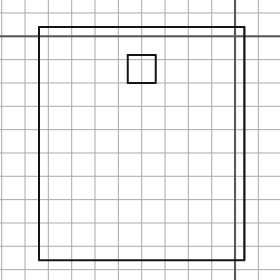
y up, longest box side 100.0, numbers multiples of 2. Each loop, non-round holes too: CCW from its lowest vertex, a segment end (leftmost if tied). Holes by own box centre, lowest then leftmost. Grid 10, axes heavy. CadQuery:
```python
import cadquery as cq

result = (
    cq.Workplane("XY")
    .moveTo(-84.0, -96.0)
    .lineTo(4.0, -96.0)
    .lineTo(4.0, 4.0)
    .lineTo(-84.0, 4.0)
    .close()
    .moveTo(-46.0, -20.0)
    .lineTo(-34.0, -20.0)
    .lineTo(-34.0, -8.0)
    .lineTo(-46.0, -8.0)
    .close()
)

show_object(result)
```